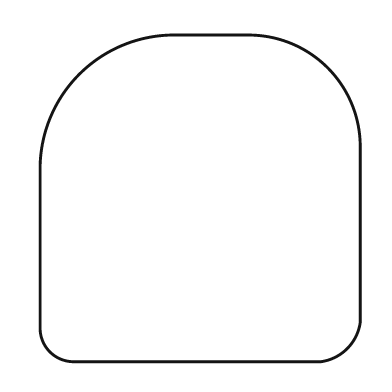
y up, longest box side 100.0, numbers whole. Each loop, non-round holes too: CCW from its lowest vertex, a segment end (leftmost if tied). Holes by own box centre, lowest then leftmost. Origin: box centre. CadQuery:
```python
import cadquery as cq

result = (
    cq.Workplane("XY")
    .moveTo(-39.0, -50.0)
    .lineTo(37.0, -50.0)
    .threePointArc((45.0, -46.0), (49.0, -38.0))
    .lineTo(49.0, 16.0)
    .threePointArc((39.0, 40.0), (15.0, 50.0))
    .lineTo(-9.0, 50.0)
    .threePointArc((-37.0, 38.0), (-49.0, 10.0))
    .lineTo(-49.0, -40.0)
    .threePointArc((-46.0, -47.0), (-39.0, -50.0))
    .close()
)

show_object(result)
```